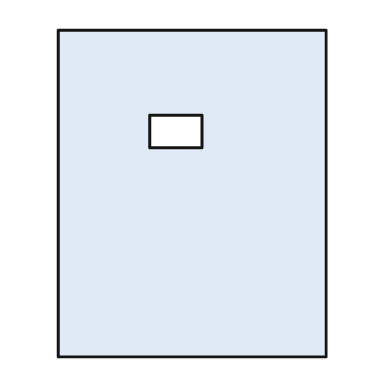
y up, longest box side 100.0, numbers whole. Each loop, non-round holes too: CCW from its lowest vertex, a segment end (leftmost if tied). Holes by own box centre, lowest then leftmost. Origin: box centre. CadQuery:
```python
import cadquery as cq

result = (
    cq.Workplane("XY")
    .moveTo(-41.0, -50.0)
    .lineTo(41.0, -50.0)
    .lineTo(41.0, 50.0)
    .lineTo(-41.0, 50.0)
    .close()
    .moveTo(-13.0, 14.0)
    .lineTo(3.0, 14.0)
    .lineTo(3.0, 24.0)
    .lineTo(-13.0, 24.0)
    .close()
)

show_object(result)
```